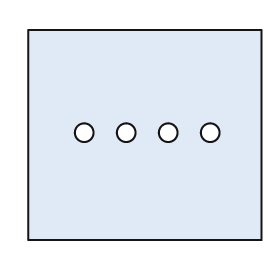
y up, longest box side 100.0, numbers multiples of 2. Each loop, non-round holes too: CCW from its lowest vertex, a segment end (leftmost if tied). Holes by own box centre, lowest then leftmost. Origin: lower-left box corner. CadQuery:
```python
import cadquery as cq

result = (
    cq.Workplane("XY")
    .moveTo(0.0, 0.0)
    .lineTo(100.0, 0.0)
    .lineTo(100.0, 90.0)
    .lineTo(0.0, 90.0)
    .close()
    .moveTo(24.0, 46.0)
    .circle(4.0)
    .moveTo(42.0, 46.0)
    .circle(4.0)
    .moveTo(60.0, 46.0)
    .circle(4.0)
    .moveTo(78.0, 46.0)
    .circle(4.0)
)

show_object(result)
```